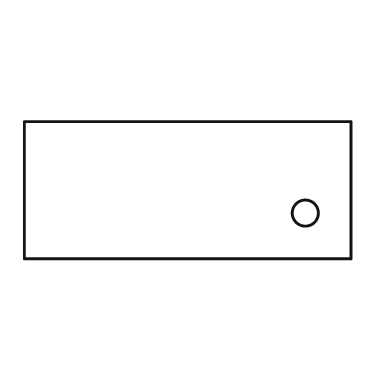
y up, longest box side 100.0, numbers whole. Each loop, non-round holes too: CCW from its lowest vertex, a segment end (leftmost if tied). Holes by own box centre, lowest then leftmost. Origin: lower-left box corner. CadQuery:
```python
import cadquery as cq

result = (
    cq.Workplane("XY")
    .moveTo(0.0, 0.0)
    .lineTo(100.0, 0.0)
    .lineTo(100.0, 42.0)
    .lineTo(0.0, 42.0)
    .close()
    .moveTo(86.0, 14.0)
    .circle(4.0)
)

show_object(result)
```